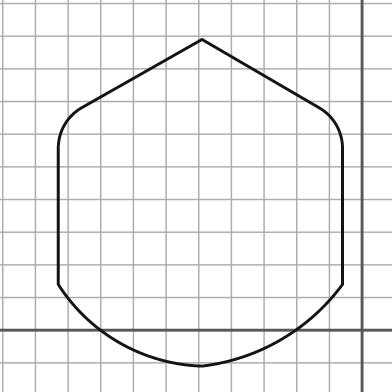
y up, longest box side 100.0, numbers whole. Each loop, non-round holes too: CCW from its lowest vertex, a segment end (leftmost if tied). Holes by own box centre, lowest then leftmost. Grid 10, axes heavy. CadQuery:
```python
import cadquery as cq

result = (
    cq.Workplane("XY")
    .moveTo(-49.0, -11.0)
    .threePointArc((-25.0, -3.0), (-6.0, 14.0))
    .lineTo(-6.0, 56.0)
    .threePointArc((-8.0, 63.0), (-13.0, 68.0))
    .lineTo(-49.0, 89.0)
    .lineTo(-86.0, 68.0)
    .threePointArc((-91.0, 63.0), (-93.0, 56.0))
    .lineTo(-93.0, 14.0)
    .threePointArc((-74.0, -4.0), (-49.0, -11.0))
    .close()
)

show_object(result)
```